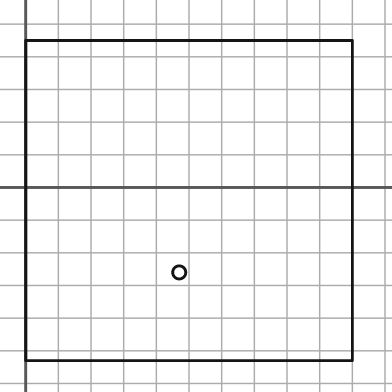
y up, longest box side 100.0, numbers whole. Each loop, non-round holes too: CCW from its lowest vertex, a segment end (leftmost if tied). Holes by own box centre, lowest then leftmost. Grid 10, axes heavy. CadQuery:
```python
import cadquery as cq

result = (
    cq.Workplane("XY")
    .moveTo(0.0, -53.0)
    .lineTo(100.0, -53.0)
    .lineTo(100.0, 45.0)
    .lineTo(0.0, 45.0)
    .close()
    .moveTo(47.0, -26.0)
    .circle(2.0)
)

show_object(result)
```